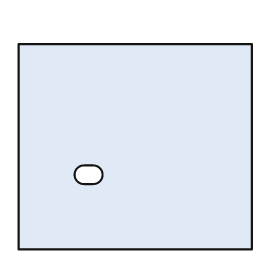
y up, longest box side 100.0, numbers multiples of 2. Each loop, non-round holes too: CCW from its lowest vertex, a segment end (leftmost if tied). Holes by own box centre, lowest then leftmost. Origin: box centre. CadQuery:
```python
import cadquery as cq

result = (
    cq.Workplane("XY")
    .moveTo(-50.0, -44.0)
    .lineTo(50.0, -44.0)
    .lineTo(50.0, 44.0)
    .lineTo(-50.0, 44.0)
    .close()
    .moveTo(-22.0, -16.0)
    .lineTo(-18.0, -16.0)
    .threePointArc((-14.0, -12.0), (-18.0, -8.0))
    .lineTo(-22.0, -8.0)
    .threePointArc((-26.0, -12.0), (-22.0, -16.0))
    .close()
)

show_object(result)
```